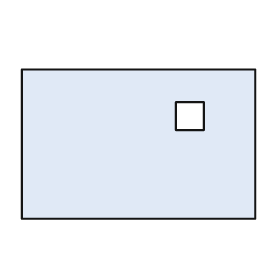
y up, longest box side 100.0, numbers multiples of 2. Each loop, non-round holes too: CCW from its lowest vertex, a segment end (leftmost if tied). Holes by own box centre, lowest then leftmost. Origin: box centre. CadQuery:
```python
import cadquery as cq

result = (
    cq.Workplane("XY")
    .moveTo(-50.0, -32.0)
    .lineTo(50.0, -32.0)
    .lineTo(50.0, 32.0)
    .lineTo(-50.0, 32.0)
    .close()
    .moveTo(16.0, 6.0)
    .lineTo(28.0, 6.0)
    .lineTo(28.0, 18.0)
    .lineTo(16.0, 18.0)
    .close()
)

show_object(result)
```